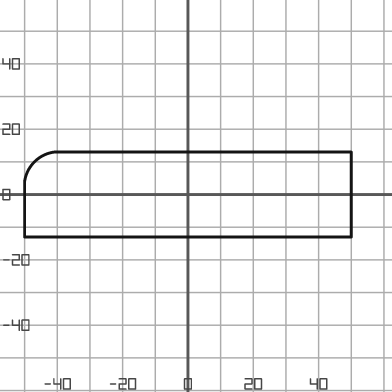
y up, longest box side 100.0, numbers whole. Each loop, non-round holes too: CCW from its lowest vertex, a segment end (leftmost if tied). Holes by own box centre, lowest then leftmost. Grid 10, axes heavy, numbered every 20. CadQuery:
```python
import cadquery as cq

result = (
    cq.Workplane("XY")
    .moveTo(-50.0, -13.0)
    .lineTo(50.0, -13.0)
    .lineTo(50.0, 13.0)
    .lineTo(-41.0, 13.0)
    .threePointArc((-47.0, 10.0), (-50.0, 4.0))
    .close()
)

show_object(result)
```